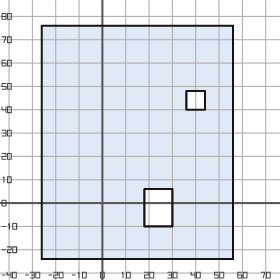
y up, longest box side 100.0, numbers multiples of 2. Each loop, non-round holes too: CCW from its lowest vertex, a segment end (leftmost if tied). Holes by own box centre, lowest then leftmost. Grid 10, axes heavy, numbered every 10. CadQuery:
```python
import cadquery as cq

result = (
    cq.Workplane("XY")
    .moveTo(-26.0, -24.0)
    .lineTo(56.0, -24.0)
    .lineTo(56.0, 76.0)
    .lineTo(-26.0, 76.0)
    .close()
    .moveTo(18.0, -10.0)
    .lineTo(30.0, -10.0)
    .lineTo(30.0, 6.0)
    .lineTo(18.0, 6.0)
    .close()
    .moveTo(36.0, 40.0)
    .lineTo(44.0, 40.0)
    .lineTo(44.0, 48.0)
    .lineTo(36.0, 48.0)
    .close()
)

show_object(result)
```